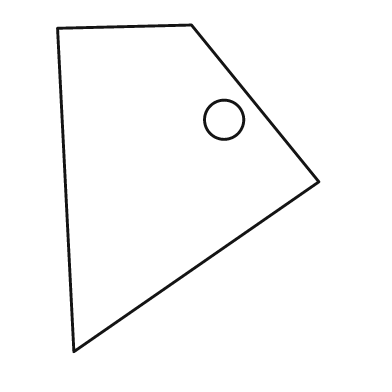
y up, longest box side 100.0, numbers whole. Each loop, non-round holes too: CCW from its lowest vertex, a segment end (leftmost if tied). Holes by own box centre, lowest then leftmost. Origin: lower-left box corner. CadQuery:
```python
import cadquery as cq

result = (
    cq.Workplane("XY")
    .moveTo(5.0, 0.0)
    .lineTo(80.0, 52.0)
    .lineTo(41.0, 100.0)
    .lineTo(0.0, 99.0)
    .close()
    .moveTo(51.0, 71.0)
    .circle(6.0)
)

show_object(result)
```